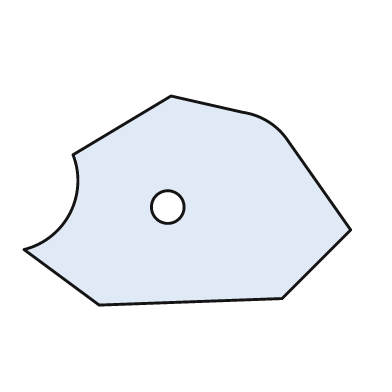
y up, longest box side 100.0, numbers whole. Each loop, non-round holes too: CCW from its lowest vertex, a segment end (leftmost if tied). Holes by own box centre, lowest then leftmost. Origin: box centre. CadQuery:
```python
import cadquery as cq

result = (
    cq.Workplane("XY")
    .moveTo(-27.0, -32.0)
    .lineTo(29.0, -30.0)
    .lineTo(50.0, -9.0)
    .lineTo(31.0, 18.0)
    .threePointArc((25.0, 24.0), (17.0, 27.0))
    .lineTo(-5.0, 32.0)
    .lineTo(-35.0, 14.0)
    .threePointArc((-36.0, -4.0), (-50.0, -15.0))
    .close()
    .moveTo(-6.0, -2.0)
    .circle(5.0)
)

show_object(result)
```